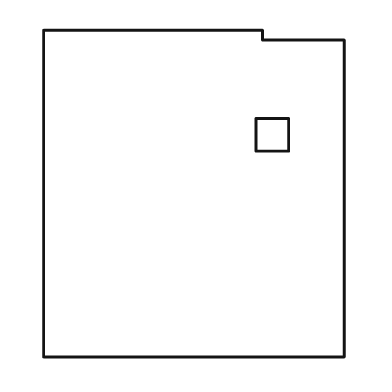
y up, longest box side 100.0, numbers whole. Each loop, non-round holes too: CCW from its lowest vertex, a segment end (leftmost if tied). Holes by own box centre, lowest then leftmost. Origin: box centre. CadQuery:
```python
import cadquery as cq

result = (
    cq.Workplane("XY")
    .moveTo(-46.0, -50.0)
    .lineTo(46.0, -50.0)
    .lineTo(46.0, 47.0)
    .lineTo(21.0, 47.0)
    .lineTo(21.0, 50.0)
    .lineTo(-46.0, 50.0)
    .close()
    .moveTo(19.0, 13.0)
    .lineTo(29.0, 13.0)
    .lineTo(29.0, 23.0)
    .lineTo(19.0, 23.0)
    .close()
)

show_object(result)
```